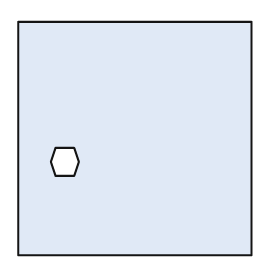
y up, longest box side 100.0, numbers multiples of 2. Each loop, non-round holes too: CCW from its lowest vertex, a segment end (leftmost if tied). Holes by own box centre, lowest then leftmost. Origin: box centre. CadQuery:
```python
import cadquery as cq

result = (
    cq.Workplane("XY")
    .moveTo(-50.0, -50.0)
    .lineTo(50.0, -50.0)
    .lineTo(50.0, 50.0)
    .lineTo(-50.0, 50.0)
    .close()
    .moveTo(-34.0, -16.0)
    .lineTo(-26.0, -16.0)
    .lineTo(-24.0, -10.0)
    .lineTo(-26.0, -4.0)
    .lineTo(-34.0, -4.0)
    .lineTo(-36.0, -10.0)
    .close()
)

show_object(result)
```